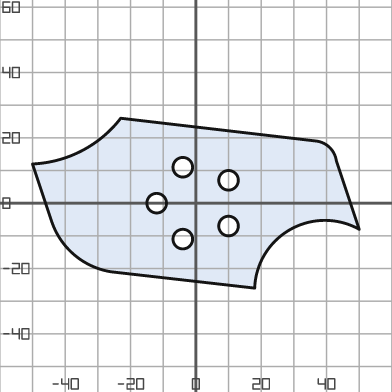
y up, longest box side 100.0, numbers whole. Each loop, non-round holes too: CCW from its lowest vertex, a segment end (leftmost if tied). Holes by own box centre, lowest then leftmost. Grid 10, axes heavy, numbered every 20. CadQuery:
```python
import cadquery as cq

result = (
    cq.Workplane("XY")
    .moveTo(18.0, -26.0)
    .threePointArc((29.0, -8.0), (50.0, -8.0))
    .lineTo(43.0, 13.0)
    .threePointArc((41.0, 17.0), (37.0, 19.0))
    .lineTo(-23.0, 26.0)
    .threePointArc((-35.0, 16.0), (-50.0, 12.0))
    .lineTo(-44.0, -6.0)
    .threePointArc((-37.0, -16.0), (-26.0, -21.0))
    .close()
    .moveTo(-4.0, -11.0)
    .circle(3.0)
    .moveTo(10.0, -7.0)
    .circle(3.0)
    .moveTo(-12.0, 0.0)
    .circle(3.0)
    .moveTo(10.0, 7.0)
    .circle(3.0)
    .moveTo(-4.0, 11.0)
    .circle(3.0)
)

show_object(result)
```